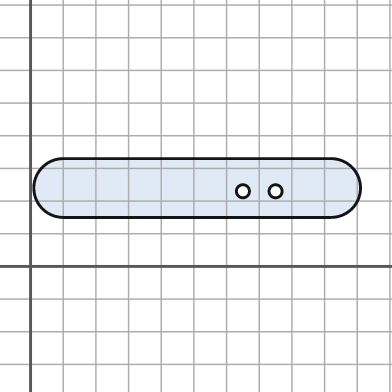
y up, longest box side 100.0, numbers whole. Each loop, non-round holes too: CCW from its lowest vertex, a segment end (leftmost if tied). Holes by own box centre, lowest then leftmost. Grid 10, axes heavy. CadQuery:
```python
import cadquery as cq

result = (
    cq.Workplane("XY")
    .moveTo(10.0, 15.0)
    .lineTo(92.0, 15.0)
    .threePointArc((101.0, 24.0), (92.0, 33.0))
    .lineTo(10.0, 33.0)
    .threePointArc((1.0, 24.0), (10.0, 15.0))
    .close()
    .moveTo(65.0, 23.0)
    .circle(2.0)
    .moveTo(75.0, 23.0)
    .circle(2.0)
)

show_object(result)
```